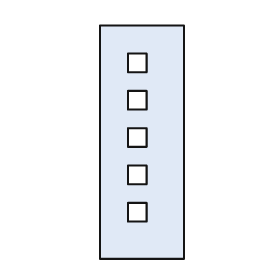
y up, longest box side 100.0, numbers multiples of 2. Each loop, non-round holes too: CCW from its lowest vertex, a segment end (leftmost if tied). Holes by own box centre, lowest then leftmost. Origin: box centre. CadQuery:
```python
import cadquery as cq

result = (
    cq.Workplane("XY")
    .moveTo(-18.0, -50.0)
    .lineTo(18.0, -50.0)
    .lineTo(18.0, 50.0)
    .lineTo(-18.0, 50.0)
    .close()
    .moveTo(-6.0, -34.0)
    .lineTo(2.0, -34.0)
    .lineTo(2.0, -26.0)
    .lineTo(-6.0, -26.0)
    .close()
    .moveTo(-6.0, -18.0)
    .lineTo(2.0, -18.0)
    .lineTo(2.0, -10.0)
    .lineTo(-6.0, -10.0)
    .close()
    .moveTo(-6.0, -2.0)
    .lineTo(2.0, -2.0)
    .lineTo(2.0, 6.0)
    .lineTo(-6.0, 6.0)
    .close()
    .moveTo(-6.0, 14.0)
    .lineTo(2.0, 14.0)
    .lineTo(2.0, 22.0)
    .lineTo(-6.0, 22.0)
    .close()
    .moveTo(-6.0, 30.0)
    .lineTo(2.0, 30.0)
    .lineTo(2.0, 38.0)
    .lineTo(-6.0, 38.0)
    .close()
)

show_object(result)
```